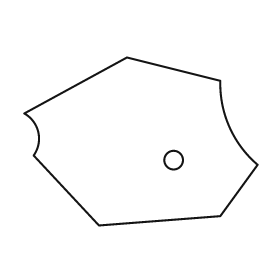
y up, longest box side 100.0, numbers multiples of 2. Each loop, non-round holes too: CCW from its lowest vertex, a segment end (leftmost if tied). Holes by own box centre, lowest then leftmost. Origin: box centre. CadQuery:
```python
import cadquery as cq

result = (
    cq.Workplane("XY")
    .moveTo(-18.0, -36.0)
    .lineTo(34.0, -32.0)
    .lineTo(50.0, -10.0)
    .threePointArc((38.0, 6.0), (34.0, 26.0))
    .lineTo(-6.0, 36.0)
    .lineTo(-50.0, 12.0)
    .threePointArc((-44.0, 4.0), (-46.0, -6.0))
    .close()
    .moveTo(14.0, -8.0)
    .circle(4.0)
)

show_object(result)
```